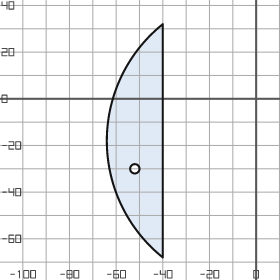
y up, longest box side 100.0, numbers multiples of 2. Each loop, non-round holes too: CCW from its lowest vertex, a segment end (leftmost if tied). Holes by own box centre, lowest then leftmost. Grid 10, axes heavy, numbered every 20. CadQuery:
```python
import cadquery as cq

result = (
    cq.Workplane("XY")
    .moveTo(-40.0, -68.0)
    .lineTo(-40.0, 32.0)
    .threePointArc((-64.0, -18.0), (-40.0, -68.0))
    .close()
    .moveTo(-52.0, -30.0)
    .circle(2.0)
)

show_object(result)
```